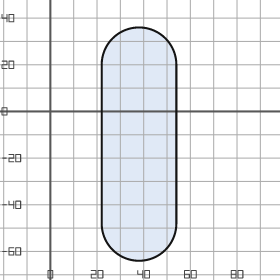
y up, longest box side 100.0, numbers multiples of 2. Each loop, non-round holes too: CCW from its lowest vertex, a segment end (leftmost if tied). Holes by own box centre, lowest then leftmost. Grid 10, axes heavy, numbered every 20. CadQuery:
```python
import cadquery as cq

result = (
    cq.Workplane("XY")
    .moveTo(22.0, -48.0)
    .threePointArc((38.0, -64.0), (54.0, -48.0))
    .lineTo(54.0, 20.0)
    .threePointArc((38.0, 36.0), (22.0, 20.0))
    .close()
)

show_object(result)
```